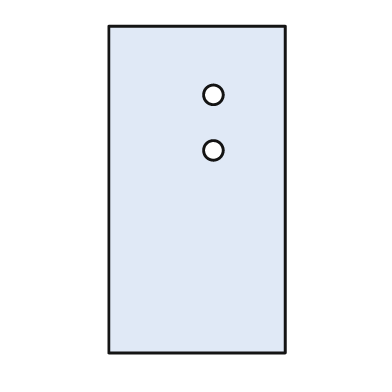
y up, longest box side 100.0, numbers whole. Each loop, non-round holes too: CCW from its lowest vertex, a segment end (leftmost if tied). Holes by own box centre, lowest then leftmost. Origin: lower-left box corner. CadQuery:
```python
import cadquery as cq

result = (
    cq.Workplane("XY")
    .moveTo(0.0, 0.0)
    .lineTo(54.0, 0.0)
    .lineTo(54.0, 100.0)
    .lineTo(0.0, 100.0)
    .close()
    .moveTo(32.0, 62.0)
    .circle(3.0)
    .moveTo(32.0, 79.0)
    .circle(3.0)
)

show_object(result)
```